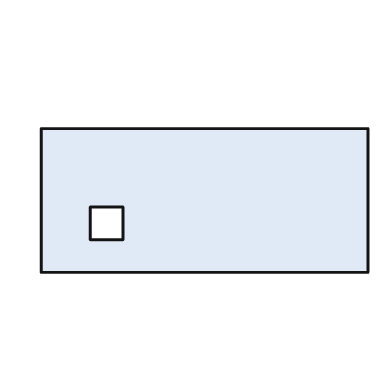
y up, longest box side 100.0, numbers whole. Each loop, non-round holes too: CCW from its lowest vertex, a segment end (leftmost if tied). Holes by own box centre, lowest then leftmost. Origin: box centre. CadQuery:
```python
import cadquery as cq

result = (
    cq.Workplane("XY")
    .moveTo(-50.0, -22.0)
    .lineTo(50.0, -22.0)
    .lineTo(50.0, 22.0)
    .lineTo(-50.0, 22.0)
    .close()
    .moveTo(-35.0, -12.0)
    .lineTo(-25.0, -12.0)
    .lineTo(-25.0, -2.0)
    .lineTo(-35.0, -2.0)
    .close()
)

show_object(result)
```